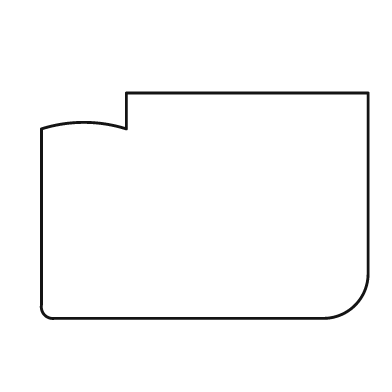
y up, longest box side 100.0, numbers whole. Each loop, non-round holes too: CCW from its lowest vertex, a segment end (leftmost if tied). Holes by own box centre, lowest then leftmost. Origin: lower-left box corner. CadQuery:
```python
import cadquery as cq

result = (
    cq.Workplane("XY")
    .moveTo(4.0, 0.0)
    .lineTo(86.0, 0.0)
    .threePointArc((96.0, 4.0), (100.0, 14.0))
    .lineTo(100.0, 69.0)
    .lineTo(26.0, 69.0)
    .lineTo(26.0, 58.0)
    .threePointArc((13.0, 60.0), (0.0, 58.0))
    .lineTo(0.0, 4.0)
    .threePointArc((1.0, 1.0), (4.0, 0.0))
    .close()
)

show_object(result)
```